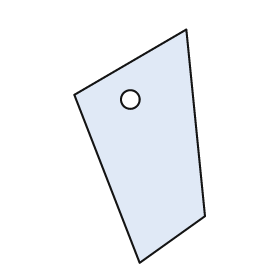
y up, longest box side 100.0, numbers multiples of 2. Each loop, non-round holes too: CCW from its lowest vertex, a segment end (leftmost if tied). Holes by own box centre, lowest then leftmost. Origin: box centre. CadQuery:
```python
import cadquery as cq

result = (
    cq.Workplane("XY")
    .moveTo(0.0, -50.0)
    .lineTo(28.0, -30.0)
    .lineTo(20.0, 50.0)
    .lineTo(-28.0, 22.0)
    .close()
    .moveTo(-4.0, 20.0)
    .circle(4.0)
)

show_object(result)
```